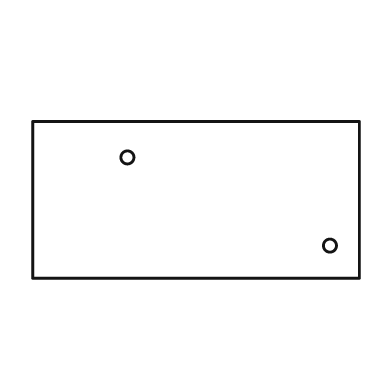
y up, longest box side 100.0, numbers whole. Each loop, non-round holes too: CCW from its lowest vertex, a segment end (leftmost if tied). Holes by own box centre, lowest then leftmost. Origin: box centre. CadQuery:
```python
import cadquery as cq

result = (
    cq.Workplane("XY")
    .moveTo(-50.0, -24.0)
    .lineTo(50.0, -24.0)
    .lineTo(50.0, 24.0)
    .lineTo(-50.0, 24.0)
    .close()
    .moveTo(41.0, -14.0)
    .circle(2.0)
    .moveTo(-21.0, 13.0)
    .circle(2.0)
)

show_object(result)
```